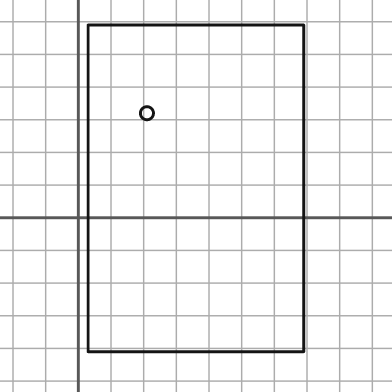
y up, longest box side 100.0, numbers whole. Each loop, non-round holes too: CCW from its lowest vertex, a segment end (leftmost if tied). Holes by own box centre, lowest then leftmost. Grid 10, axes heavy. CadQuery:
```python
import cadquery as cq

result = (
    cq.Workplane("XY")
    .moveTo(3.0, -41.0)
    .lineTo(69.0, -41.0)
    .lineTo(69.0, 59.0)
    .lineTo(3.0, 59.0)
    .close()
    .moveTo(21.0, 32.0)
    .circle(2.0)
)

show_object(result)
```